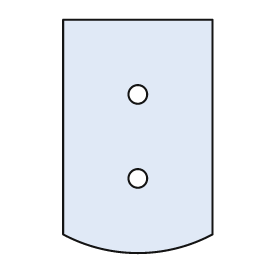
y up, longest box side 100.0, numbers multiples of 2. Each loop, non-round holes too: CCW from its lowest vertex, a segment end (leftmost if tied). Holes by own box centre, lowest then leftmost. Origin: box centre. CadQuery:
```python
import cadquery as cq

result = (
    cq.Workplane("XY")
    .moveTo(-32.0, -42.0)
    .threePointArc((0.0, -50.0), (32.0, -42.0))
    .lineTo(32.0, 50.0)
    .lineTo(-32.0, 50.0)
    .close()
    .moveTo(0.0, -18.0)
    .circle(4.0)
    .moveTo(0.0, 18.0)
    .circle(4.0)
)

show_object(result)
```